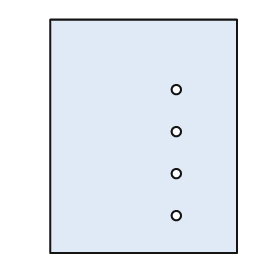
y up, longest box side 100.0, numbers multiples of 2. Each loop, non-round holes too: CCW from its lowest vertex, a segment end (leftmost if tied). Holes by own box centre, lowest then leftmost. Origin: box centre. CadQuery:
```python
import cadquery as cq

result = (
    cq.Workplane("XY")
    .moveTo(-40.0, -50.0)
    .lineTo(40.0, -50.0)
    .lineTo(40.0, 50.0)
    .lineTo(-40.0, 50.0)
    .close()
    .moveTo(14.0, -34.0)
    .circle(2.0)
    .moveTo(14.0, -16.0)
    .circle(2.0)
    .moveTo(14.0, 2.0)
    .circle(2.0)
    .moveTo(14.0, 20.0)
    .circle(2.0)
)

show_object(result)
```